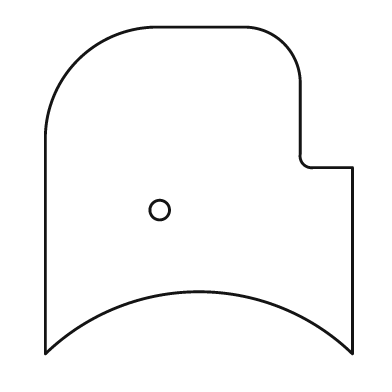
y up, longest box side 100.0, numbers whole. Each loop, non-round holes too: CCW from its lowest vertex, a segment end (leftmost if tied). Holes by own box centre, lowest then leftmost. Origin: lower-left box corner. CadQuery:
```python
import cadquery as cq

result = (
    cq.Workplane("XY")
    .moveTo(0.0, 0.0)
    .threePointArc((47.0, 19.0), (94.0, 0.0))
    .lineTo(94.0, 57.0)
    .lineTo(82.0, 57.0)
    .threePointArc((79.0, 58.0), (78.0, 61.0))
    .lineTo(78.0, 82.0)
    .threePointArc((73.0, 95.0), (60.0, 100.0))
    .lineTo(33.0, 100.0)
    .threePointArc((10.0, 90.0), (0.0, 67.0))
    .close()
    .moveTo(35.0, 44.0)
    .circle(3.0)
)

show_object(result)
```